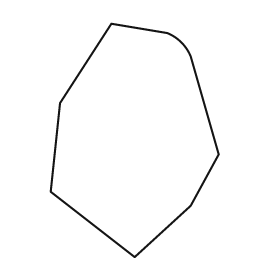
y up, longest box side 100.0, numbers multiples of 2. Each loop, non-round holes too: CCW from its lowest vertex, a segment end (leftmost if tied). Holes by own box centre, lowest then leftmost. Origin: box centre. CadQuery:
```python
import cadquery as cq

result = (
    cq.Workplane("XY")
    .moveTo(0.0, -50.0)
    .lineTo(24.0, -28.0)
    .lineTo(36.0, -6.0)
    .lineTo(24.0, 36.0)
    .threePointArc((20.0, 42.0), (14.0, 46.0))
    .lineTo(-10.0, 50.0)
    .lineTo(-32.0, 16.0)
    .lineTo(-36.0, -22.0)
    .close()
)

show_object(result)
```